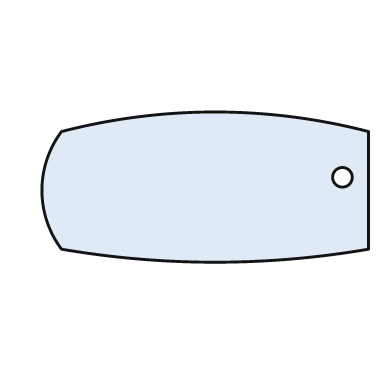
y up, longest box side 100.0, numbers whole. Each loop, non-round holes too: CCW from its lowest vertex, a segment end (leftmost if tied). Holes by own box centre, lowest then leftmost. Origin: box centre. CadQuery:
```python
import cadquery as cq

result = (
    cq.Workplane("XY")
    .moveTo(-44.0, -19.0)
    .threePointArc((3.0, -23.0), (50.0, -19.0))
    .lineTo(50.0, 17.0)
    .threePointArc((3.0, 23.0), (-44.0, 17.0))
    .threePointArc((-50.0, -1.0), (-44.0, -19.0))
    .close()
    .moveTo(42.0, 3.0)
    .circle(3.0)
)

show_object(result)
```